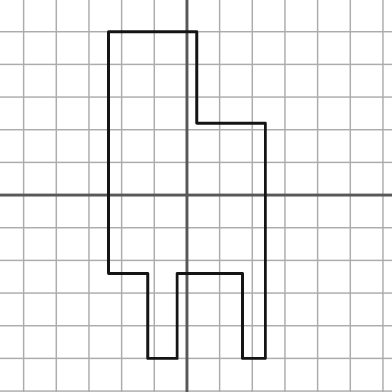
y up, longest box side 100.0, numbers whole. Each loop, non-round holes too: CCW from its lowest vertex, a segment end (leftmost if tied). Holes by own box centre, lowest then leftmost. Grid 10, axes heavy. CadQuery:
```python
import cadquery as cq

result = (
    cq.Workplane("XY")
    .moveTo(-12.0, -50.0)
    .lineTo(-3.0, -50.0)
    .lineTo(-3.0, -24.0)
    .lineTo(17.0, -24.0)
    .lineTo(17.0, -50.0)
    .lineTo(24.0, -50.0)
    .lineTo(24.0, 22.0)
    .lineTo(3.0, 22.0)
    .lineTo(3.0, 50.0)
    .lineTo(-24.0, 50.0)
    .lineTo(-24.0, -24.0)
    .lineTo(-12.0, -24.0)
    .close()
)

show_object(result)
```